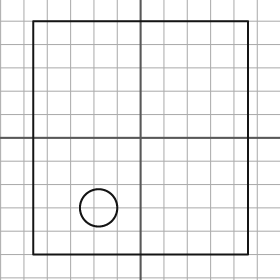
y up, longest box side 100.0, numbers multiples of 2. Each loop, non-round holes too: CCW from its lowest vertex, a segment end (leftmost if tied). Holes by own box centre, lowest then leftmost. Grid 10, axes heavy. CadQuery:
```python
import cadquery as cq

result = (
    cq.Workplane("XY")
    .moveTo(-46.0, -50.0)
    .lineTo(46.0, -50.0)
    .lineTo(46.0, 50.0)
    .lineTo(-46.0, 50.0)
    .close()
    .moveTo(-18.0, -30.0)
    .circle(8.0)
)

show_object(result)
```